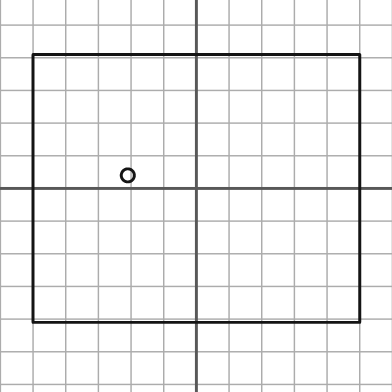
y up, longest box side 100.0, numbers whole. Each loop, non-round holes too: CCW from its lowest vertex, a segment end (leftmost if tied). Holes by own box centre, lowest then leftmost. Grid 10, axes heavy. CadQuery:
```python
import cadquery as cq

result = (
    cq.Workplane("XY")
    .moveTo(-50.0, -41.0)
    .lineTo(50.0, -41.0)
    .lineTo(50.0, 41.0)
    .lineTo(-50.0, 41.0)
    .close()
    .moveTo(-21.0, 4.0)
    .circle(2.0)
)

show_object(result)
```